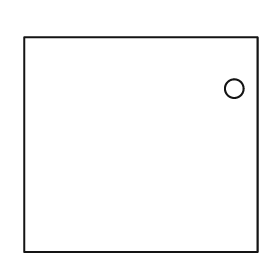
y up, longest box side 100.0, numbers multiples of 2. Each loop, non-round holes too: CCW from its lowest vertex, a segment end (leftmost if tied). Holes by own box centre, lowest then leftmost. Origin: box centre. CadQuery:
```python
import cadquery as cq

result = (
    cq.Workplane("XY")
    .moveTo(-50.0, -46.0)
    .lineTo(50.0, -46.0)
    .lineTo(50.0, 46.0)
    .lineTo(-50.0, 46.0)
    .close()
    .moveTo(40.0, 24.0)
    .circle(4.0)
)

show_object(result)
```